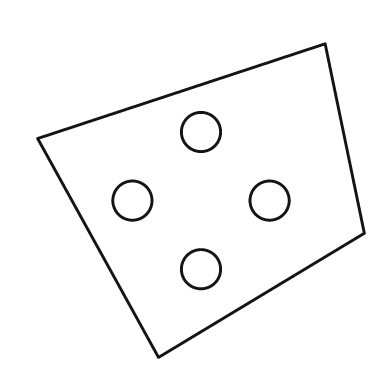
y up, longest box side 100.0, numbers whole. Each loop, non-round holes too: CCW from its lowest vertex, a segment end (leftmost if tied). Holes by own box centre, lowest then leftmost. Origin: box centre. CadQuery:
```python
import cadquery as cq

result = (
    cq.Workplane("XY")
    .moveTo(-13.0, -48.0)
    .lineTo(50.0, -10.0)
    .lineTo(38.0, 48.0)
    .lineTo(-50.0, 19.0)
    .close()
    .moveTo(0.0, -21.0)
    .circle(6.0)
    .moveTo(-21.0, 0.0)
    .circle(6.0)
    .moveTo(21.0, 0.0)
    .circle(6.0)
    .moveTo(0.0, 21.0)
    .circle(6.0)
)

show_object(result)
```